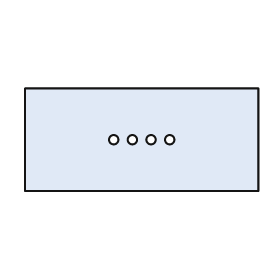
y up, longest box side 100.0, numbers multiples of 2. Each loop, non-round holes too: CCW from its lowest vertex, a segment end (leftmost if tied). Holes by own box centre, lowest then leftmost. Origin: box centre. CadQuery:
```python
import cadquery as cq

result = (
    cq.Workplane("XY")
    .moveTo(-50.0, -22.0)
    .lineTo(50.0, -22.0)
    .lineTo(50.0, 22.0)
    .lineTo(-50.0, 22.0)
    .close()
    .moveTo(-12.0, 0.0)
    .circle(2.0)
    .moveTo(-4.0, 0.0)
    .circle(2.0)
    .moveTo(4.0, 0.0)
    .circle(2.0)
    .moveTo(12.0, 0.0)
    .circle(2.0)
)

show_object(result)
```